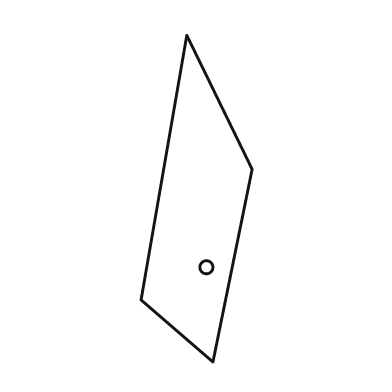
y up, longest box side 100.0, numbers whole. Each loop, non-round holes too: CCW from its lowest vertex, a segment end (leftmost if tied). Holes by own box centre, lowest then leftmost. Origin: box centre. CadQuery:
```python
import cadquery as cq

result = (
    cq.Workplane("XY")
    .moveTo(5.0, -50.0)
    .lineTo(17.0, 9.0)
    .lineTo(-3.0, 50.0)
    .lineTo(-17.0, -31.0)
    .close()
    .moveTo(3.0, -21.0)
    .circle(2.0)
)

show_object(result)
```